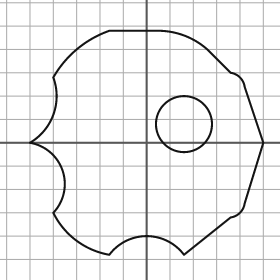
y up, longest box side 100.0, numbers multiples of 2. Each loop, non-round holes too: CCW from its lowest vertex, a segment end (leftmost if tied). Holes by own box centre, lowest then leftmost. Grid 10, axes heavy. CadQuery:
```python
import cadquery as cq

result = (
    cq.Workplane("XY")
    .moveTo(-16.0, -48.0)
    .threePointArc((0.0, -40.0), (16.0, -48.0))
    .lineTo(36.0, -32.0)
    .threePointArc((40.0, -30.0), (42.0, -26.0))
    .lineTo(50.0, 0.0)
    .lineTo(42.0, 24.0)
    .threePointArc((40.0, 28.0), (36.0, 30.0))
    .lineTo(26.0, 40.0)
    .threePointArc((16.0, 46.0), (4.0, 48.0))
    .lineTo(-16.0, 48.0)
    .threePointArc((-30.0, 40.0), (-40.0, 28.0))
    .threePointArc((-40.0, 12.0), (-50.0, 0.0))
    .threePointArc((-36.0, -12.0), (-40.0, -30.0))
    .threePointArc((-30.0, -42.0), (-16.0, -48.0))
    .close()
    .moveTo(16.0, 8.0)
    .circle(12.0)
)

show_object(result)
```